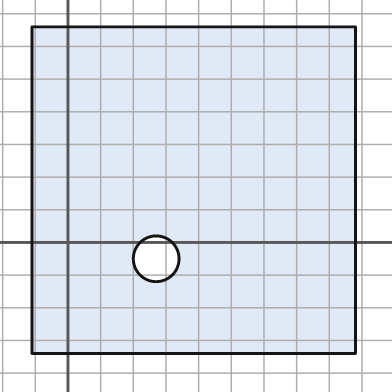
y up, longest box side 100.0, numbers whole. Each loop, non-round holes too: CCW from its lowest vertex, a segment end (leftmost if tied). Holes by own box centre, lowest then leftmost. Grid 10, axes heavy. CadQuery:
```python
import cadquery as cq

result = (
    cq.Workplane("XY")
    .moveTo(-11.0, -34.0)
    .lineTo(88.0, -34.0)
    .lineTo(88.0, 66.0)
    .lineTo(-11.0, 66.0)
    .close()
    .moveTo(27.0, -5.0)
    .circle(7.0)
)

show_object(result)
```